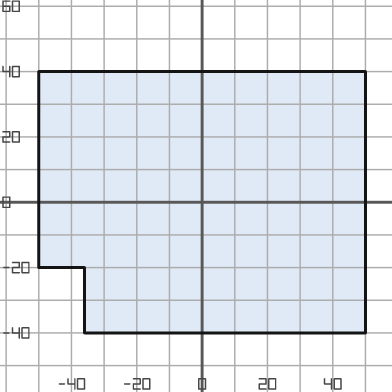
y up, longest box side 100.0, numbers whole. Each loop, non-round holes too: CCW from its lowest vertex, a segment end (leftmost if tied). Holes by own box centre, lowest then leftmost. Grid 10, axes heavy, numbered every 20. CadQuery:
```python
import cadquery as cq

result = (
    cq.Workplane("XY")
    .moveTo(-36.0, -40.0)
    .lineTo(50.0, -40.0)
    .lineTo(50.0, 40.0)
    .lineTo(-50.0, 40.0)
    .lineTo(-50.0, -20.0)
    .lineTo(-36.0, -20.0)
    .close()
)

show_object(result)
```